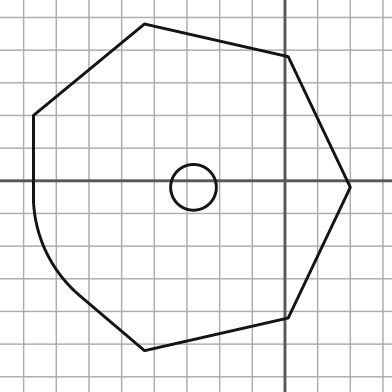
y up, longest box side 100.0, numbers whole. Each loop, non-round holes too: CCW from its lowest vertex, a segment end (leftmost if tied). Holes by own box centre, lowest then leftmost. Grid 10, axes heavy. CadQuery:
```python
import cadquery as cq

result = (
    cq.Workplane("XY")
    .moveTo(-43.0, -52.0)
    .lineTo(1.0, -42.0)
    .lineTo(20.0, -2.0)
    .lineTo(1.0, 38.0)
    .lineTo(-43.0, 48.0)
    .lineTo(-77.0, 20.0)
    .lineTo(-77.0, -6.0)
    .threePointArc((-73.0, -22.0), (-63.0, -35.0))
    .close()
    .moveTo(-28.0, -2.0)
    .circle(7.0)
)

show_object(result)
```